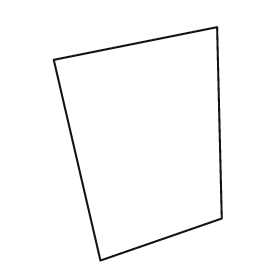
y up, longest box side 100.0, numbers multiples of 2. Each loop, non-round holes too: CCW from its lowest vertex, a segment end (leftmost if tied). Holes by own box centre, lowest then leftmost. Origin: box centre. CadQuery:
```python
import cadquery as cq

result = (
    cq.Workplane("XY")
    .moveTo(-16.0, -50.0)
    .lineTo(36.0, -32.0)
    .lineTo(34.0, 50.0)
    .lineTo(-36.0, 36.0)
    .close()
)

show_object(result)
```